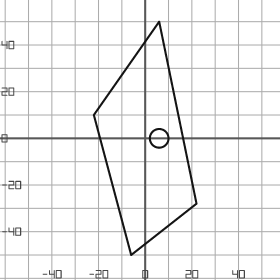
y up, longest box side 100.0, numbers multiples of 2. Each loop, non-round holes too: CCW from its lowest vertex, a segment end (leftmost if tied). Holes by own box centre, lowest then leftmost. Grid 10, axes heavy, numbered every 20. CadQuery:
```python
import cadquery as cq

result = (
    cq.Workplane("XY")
    .moveTo(-6.0, -50.0)
    .lineTo(22.0, -28.0)
    .lineTo(6.0, 50.0)
    .lineTo(-22.0, 10.0)
    .close()
    .moveTo(6.0, 0.0)
    .circle(4.0)
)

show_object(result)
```